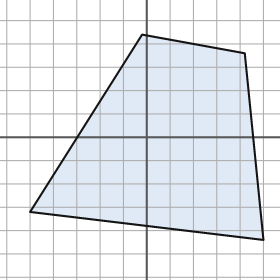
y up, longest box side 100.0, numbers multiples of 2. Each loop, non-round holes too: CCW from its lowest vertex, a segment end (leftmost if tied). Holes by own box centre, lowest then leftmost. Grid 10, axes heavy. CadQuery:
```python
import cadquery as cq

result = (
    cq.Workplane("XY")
    .moveTo(50.0, -44.0)
    .lineTo(42.0, 36.0)
    .lineTo(-2.0, 44.0)
    .lineTo(-50.0, -32.0)
    .close()
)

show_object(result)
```